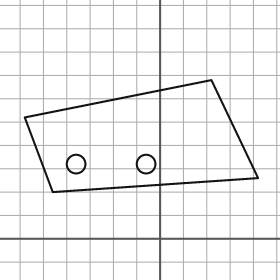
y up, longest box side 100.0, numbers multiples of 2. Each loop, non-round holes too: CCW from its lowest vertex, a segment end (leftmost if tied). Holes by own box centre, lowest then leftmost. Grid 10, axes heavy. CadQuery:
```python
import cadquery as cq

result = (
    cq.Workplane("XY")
    .moveTo(-46.0, 20.0)
    .lineTo(42.0, 26.0)
    .lineTo(22.0, 68.0)
    .lineTo(-58.0, 52.0)
    .close()
    .moveTo(-36.0, 32.0)
    .circle(4.0)
    .moveTo(-6.0, 32.0)
    .circle(4.0)
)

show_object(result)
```